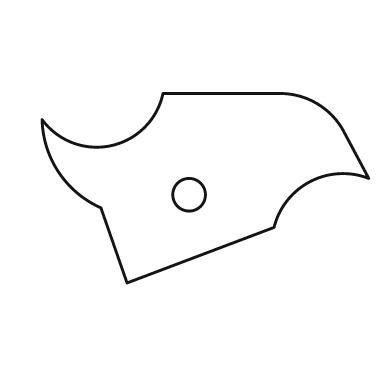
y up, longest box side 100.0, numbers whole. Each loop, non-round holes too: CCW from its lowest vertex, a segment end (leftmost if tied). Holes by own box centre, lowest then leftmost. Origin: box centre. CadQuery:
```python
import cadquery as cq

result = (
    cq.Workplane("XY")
    .moveTo(-24.0, -29.0)
    .lineTo(21.0, -12.0)
    .threePointArc((32.0, 2.0), (50.0, 3.0))
    .lineTo(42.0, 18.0)
    .threePointArc((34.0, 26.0), (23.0, 29.0))
    .lineTo(-13.0, 29.0)
    .threePointArc((-29.0, 13.0), (-50.0, 21.0))
    .threePointArc((-45.0, 5.0), (-32.0, -6.0))
    .close()
    .moveTo(-5.0, -2.0)
    .circle(5.0)
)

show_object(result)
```